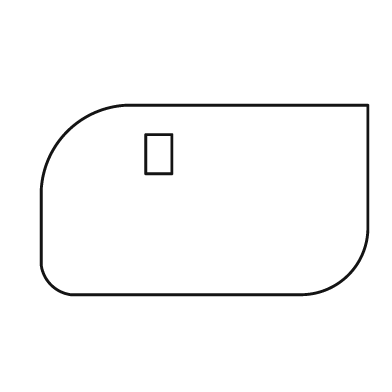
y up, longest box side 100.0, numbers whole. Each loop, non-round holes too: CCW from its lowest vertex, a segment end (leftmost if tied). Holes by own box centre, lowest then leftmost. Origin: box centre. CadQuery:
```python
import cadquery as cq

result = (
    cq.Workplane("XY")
    .moveTo(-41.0, -29.0)
    .lineTo(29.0, -29.0)
    .threePointArc((44.0, -23.0), (50.0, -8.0))
    .lineTo(50.0, 29.0)
    .lineTo(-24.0, 29.0)
    .threePointArc((-42.0, 21.0), (-50.0, 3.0))
    .lineTo(-50.0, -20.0)
    .threePointArc((-47.0, -26.0), (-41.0, -29.0))
    .close()
    .moveTo(-18.0, 8.0)
    .lineTo(-10.0, 8.0)
    .lineTo(-10.0, 20.0)
    .lineTo(-18.0, 20.0)
    .close()
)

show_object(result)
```